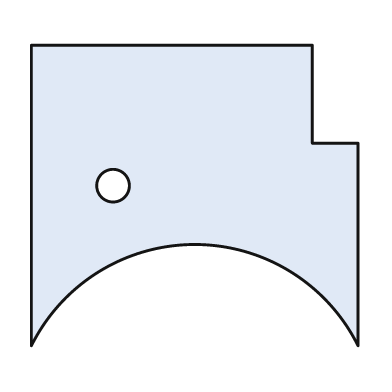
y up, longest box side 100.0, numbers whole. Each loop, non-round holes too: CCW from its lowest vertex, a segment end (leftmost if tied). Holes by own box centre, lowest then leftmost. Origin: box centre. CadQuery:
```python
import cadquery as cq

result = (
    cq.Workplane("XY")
    .moveTo(-50.0, -46.0)
    .threePointArc((0.0, -15.0), (50.0, -46.0))
    .lineTo(50.0, 16.0)
    .lineTo(36.0, 16.0)
    .lineTo(36.0, 46.0)
    .lineTo(-50.0, 46.0)
    .close()
    .moveTo(-25.0, 3.0)
    .circle(5.0)
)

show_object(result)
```